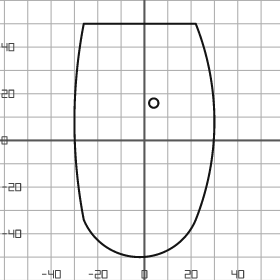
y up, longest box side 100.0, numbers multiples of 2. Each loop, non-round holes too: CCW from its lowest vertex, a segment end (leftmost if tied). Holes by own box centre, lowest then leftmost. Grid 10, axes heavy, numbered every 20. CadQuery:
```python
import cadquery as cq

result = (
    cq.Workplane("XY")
    .moveTo(-26.0, -34.0)
    .threePointArc((-2.0, -50.0), (22.0, -34.0))
    .threePointArc((30.0, 8.0), (22.0, 50.0))
    .lineTo(-26.0, 50.0)
    .threePointArc((-30.0, 8.0), (-26.0, -34.0))
    .close()
    .moveTo(4.0, 16.0)
    .circle(2.0)
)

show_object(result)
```